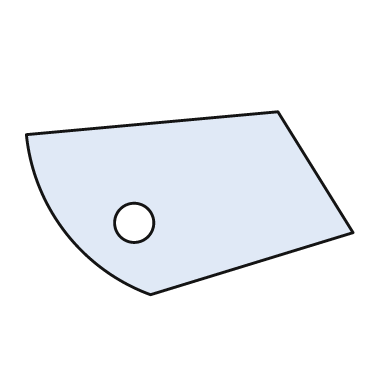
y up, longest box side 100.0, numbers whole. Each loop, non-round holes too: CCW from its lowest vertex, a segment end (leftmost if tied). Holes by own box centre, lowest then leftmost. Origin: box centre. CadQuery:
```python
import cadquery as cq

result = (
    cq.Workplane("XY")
    .moveTo(-12.0, -28.0)
    .lineTo(50.0, -9.0)
    .lineTo(27.0, 28.0)
    .lineTo(-50.0, 21.0)
    .threePointArc((-38.0, -9.0), (-12.0, -28.0))
    .close()
    .moveTo(-17.0, -6.0)
    .circle(6.0)
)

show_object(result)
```